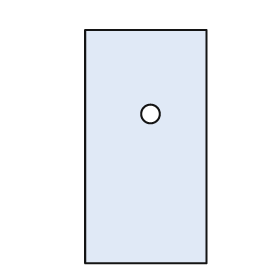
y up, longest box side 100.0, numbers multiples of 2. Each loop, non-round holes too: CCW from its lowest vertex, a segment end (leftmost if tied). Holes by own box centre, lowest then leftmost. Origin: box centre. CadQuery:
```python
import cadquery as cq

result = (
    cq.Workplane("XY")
    .moveTo(-26.0, -50.0)
    .lineTo(26.0, -50.0)
    .lineTo(26.0, 50.0)
    .lineTo(-26.0, 50.0)
    .close()
    .moveTo(2.0, 14.0)
    .circle(4.0)
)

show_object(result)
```